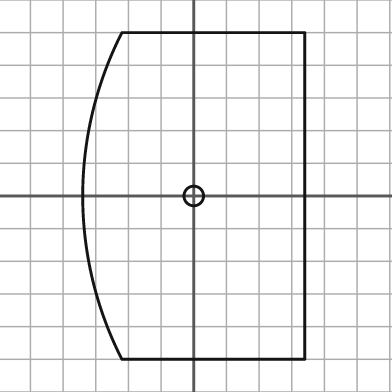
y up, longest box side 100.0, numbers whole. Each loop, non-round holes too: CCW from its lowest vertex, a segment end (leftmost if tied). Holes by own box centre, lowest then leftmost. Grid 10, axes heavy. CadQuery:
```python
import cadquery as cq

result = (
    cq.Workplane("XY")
    .moveTo(-22.0, -50.0)
    .lineTo(34.0, -50.0)
    .lineTo(34.0, 50.0)
    .lineTo(-22.0, 50.0)
    .threePointArc((-34.0, 0.0), (-22.0, -50.0))
    .close()
    .moveTo(0.0, 0.0)
    .circle(3.0)
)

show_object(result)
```